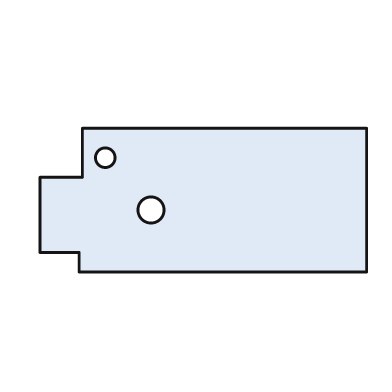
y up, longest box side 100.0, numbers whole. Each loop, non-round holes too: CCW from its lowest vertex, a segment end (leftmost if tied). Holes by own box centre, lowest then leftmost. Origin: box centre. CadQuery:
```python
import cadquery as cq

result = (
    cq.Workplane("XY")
    .moveTo(-38.0, -22.0)
    .lineTo(50.0, -22.0)
    .lineTo(50.0, 22.0)
    .lineTo(-37.0, 22.0)
    .lineTo(-37.0, 7.0)
    .lineTo(-50.0, 7.0)
    .lineTo(-50.0, -16.0)
    .lineTo(-38.0, -16.0)
    .close()
    .moveTo(-16.0, -3.0)
    .circle(4.0)
    .moveTo(-30.0, 13.0)
    .circle(3.0)
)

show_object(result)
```